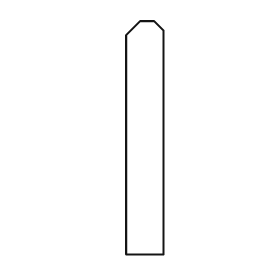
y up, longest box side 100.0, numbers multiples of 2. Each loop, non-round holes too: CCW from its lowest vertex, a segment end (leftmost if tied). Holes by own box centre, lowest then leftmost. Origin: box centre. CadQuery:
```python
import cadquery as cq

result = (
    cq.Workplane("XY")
    .moveTo(-8.0, -50.0)
    .lineTo(8.0, -50.0)
    .lineTo(8.0, 46.0)
    .lineTo(4.0, 50.0)
    .lineTo(-2.0, 50.0)
    .lineTo(-8.0, 44.0)
    .close()
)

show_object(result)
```